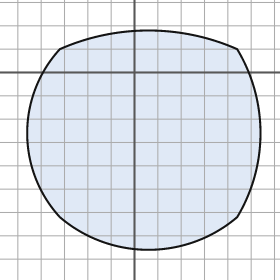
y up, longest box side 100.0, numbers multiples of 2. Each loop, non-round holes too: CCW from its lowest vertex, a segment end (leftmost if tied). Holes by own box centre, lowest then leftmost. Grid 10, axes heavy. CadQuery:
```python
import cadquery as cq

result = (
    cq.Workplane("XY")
    .moveTo(-32.0, -62.0)
    .threePointArc((6.0, -76.0), (44.0, -62.0))
    .threePointArc((54.0, -26.0), (44.0, 10.0))
    .threePointArc((6.0, 18.0), (-32.0, 10.0))
    .threePointArc((-46.0, -26.0), (-32.0, -62.0))
    .close()
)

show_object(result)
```